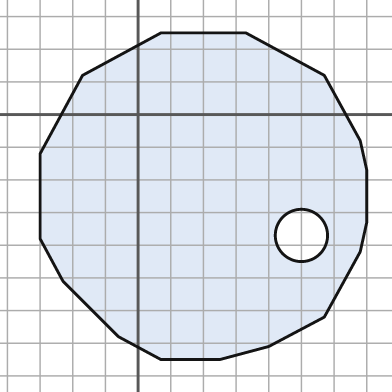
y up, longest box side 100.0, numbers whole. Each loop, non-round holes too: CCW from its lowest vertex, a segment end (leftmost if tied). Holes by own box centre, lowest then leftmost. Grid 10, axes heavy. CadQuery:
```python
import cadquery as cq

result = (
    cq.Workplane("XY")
    .moveTo(7.0, -75.0)
    .lineTo(25.0, -75.0)
    .lineTo(40.0, -71.0)
    .lineTo(57.0, -62.0)
    .lineTo(68.0, -42.0)
    .lineTo(70.0, -33.0)
    .lineTo(70.0, -17.0)
    .lineTo(68.0, -8.0)
    .lineTo(57.0, 12.0)
    .lineTo(33.0, 25.0)
    .lineTo(7.0, 25.0)
    .lineTo(-17.0, 12.0)
    .lineTo(-30.0, -12.0)
    .lineTo(-30.0, -38.0)
    .lineTo(-23.0, -51.0)
    .lineTo(-6.0, -68.0)
    .close()
    .moveTo(50.0, -37.0)
    .circle(8.0)
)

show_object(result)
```